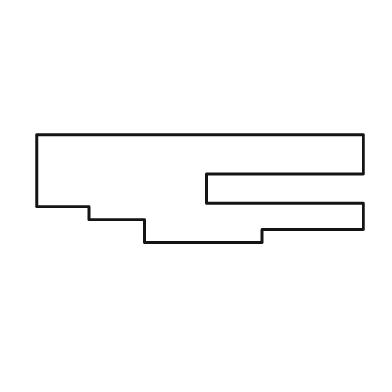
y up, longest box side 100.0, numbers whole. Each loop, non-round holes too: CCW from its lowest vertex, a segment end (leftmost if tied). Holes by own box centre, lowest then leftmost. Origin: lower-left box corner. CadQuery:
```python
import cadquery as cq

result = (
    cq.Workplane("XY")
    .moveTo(33.0, 0.0)
    .lineTo(69.0, 0.0)
    .lineTo(69.0, 4.0)
    .lineTo(100.0, 4.0)
    .lineTo(100.0, 12.0)
    .lineTo(52.0, 12.0)
    .lineTo(52.0, 21.0)
    .lineTo(100.0, 21.0)
    .lineTo(100.0, 33.0)
    .lineTo(0.0, 33.0)
    .lineTo(0.0, 11.0)
    .lineTo(16.0, 11.0)
    .lineTo(16.0, 7.0)
    .lineTo(33.0, 7.0)
    .close()
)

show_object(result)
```